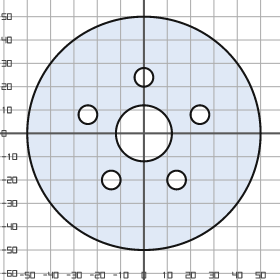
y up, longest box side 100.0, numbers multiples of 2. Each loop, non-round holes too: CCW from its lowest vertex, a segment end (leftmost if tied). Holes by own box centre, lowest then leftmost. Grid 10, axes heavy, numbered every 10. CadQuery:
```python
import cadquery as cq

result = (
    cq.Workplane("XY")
    .moveTo(0.0, 0.0)
    .circle(50.0)
    .moveTo(-14.0, -20.0)
    .circle(4.0)
    .moveTo(14.0, -20.0)
    .circle(4.0)
    .moveTo(0.0, 0.0)
    .circle(12.0)
    .moveTo(-24.0, 8.0)
    .circle(4.0)
    .moveTo(24.0, 8.0)
    .circle(4.0)
    .moveTo(0.0, 24.0)
    .circle(4.0)
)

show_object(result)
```